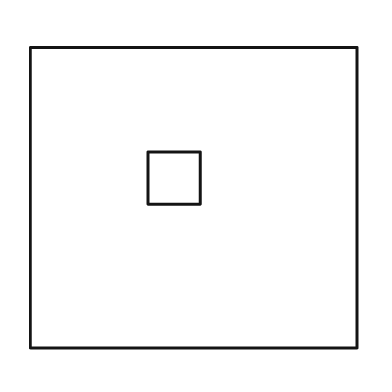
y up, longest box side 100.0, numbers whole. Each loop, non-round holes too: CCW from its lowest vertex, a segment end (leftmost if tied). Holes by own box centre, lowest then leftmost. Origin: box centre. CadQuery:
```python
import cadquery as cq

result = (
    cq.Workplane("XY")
    .moveTo(-50.0, -46.0)
    .lineTo(50.0, -46.0)
    .lineTo(50.0, 46.0)
    .lineTo(-50.0, 46.0)
    .close()
    .moveTo(-14.0, -2.0)
    .lineTo(2.0, -2.0)
    .lineTo(2.0, 14.0)
    .lineTo(-14.0, 14.0)
    .close()
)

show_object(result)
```